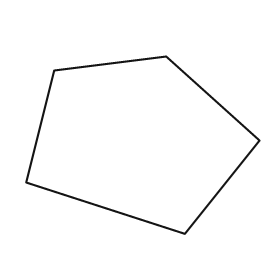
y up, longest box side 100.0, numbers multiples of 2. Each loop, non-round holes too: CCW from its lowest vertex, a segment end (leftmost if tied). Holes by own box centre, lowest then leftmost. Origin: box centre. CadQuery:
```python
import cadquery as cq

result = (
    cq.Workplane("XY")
    .moveTo(18.0, -38.0)
    .lineTo(50.0, 2.0)
    .lineTo(10.0, 38.0)
    .lineTo(-38.0, 32.0)
    .lineTo(-50.0, -16.0)
    .close()
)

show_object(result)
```